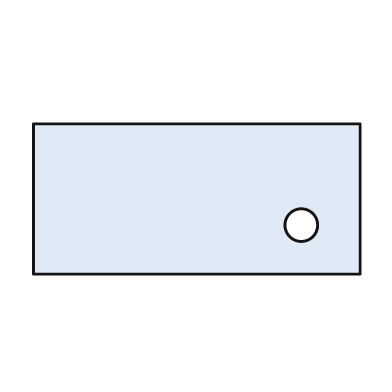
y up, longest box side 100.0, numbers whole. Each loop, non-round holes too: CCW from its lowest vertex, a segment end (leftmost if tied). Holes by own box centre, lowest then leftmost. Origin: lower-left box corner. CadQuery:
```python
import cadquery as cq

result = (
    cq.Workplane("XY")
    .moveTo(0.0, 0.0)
    .lineTo(100.0, 0.0)
    .lineTo(100.0, 46.0)
    .lineTo(0.0, 46.0)
    .close()
    .moveTo(82.0, 15.0)
    .circle(5.0)
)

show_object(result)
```